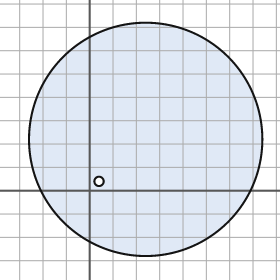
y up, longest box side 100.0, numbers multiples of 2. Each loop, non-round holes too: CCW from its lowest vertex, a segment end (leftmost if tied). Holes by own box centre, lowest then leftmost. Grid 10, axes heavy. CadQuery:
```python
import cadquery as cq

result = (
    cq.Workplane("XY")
    .moveTo(24.0, 22.0)
    .circle(50.0)
    .moveTo(4.0, 4.0)
    .circle(2.0)
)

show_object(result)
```